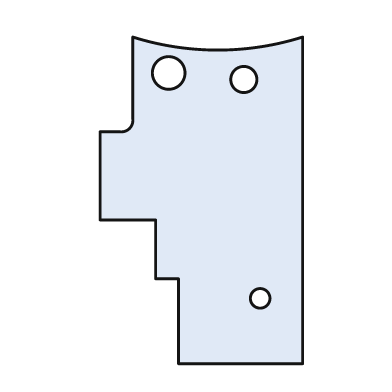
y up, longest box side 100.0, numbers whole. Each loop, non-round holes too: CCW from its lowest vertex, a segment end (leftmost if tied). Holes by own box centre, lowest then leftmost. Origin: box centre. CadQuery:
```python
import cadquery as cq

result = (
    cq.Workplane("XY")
    .moveTo(-7.0, -50.0)
    .lineTo(31.0, -50.0)
    .lineTo(31.0, 50.0)
    .threePointArc((5.0, 46.0), (-21.0, 50.0))
    .lineTo(-21.0, 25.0)
    .threePointArc((-22.0, 22.0), (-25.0, 21.0))
    .lineTo(-31.0, 21.0)
    .lineTo(-31.0, -6.0)
    .lineTo(-14.0, -6.0)
    .lineTo(-14.0, -24.0)
    .lineTo(-7.0, -24.0)
    .close()
    .moveTo(18.0, -30.0)
    .circle(3.0)
    .moveTo(13.0, 37.0)
    .circle(4.0)
    .moveTo(-10.0, 39.0)
    .circle(5.0)
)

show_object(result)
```